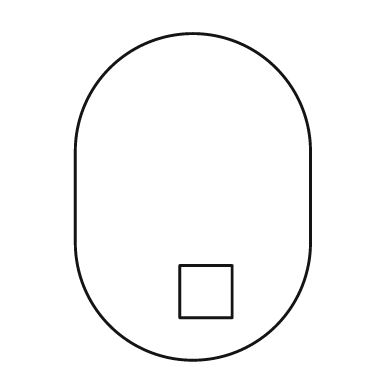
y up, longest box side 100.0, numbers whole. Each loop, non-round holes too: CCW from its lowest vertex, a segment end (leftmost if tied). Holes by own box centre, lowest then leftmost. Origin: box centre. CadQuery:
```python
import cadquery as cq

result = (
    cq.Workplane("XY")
    .moveTo(-36.0, -14.0)
    .threePointArc((0.0, -50.0), (36.0, -14.0))
    .lineTo(36.0, 14.0)
    .threePointArc((0.0, 50.0), (-36.0, 14.0))
    .close()
    .moveTo(-4.0, -37.0)
    .lineTo(12.0, -37.0)
    .lineTo(12.0, -21.0)
    .lineTo(-4.0, -21.0)
    .close()
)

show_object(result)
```